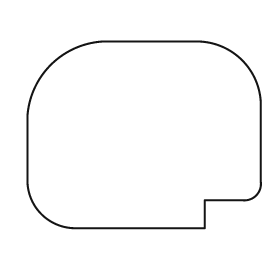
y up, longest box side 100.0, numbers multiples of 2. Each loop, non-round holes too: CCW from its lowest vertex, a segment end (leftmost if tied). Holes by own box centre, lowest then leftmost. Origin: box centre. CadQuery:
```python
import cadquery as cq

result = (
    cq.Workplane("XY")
    .moveTo(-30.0, -40.0)
    .lineTo(26.0, -40.0)
    .lineTo(26.0, -28.0)
    .lineTo(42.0, -28.0)
    .threePointArc((48.0, -26.0), (50.0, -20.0))
    .lineTo(50.0, 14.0)
    .threePointArc((42.0, 32.0), (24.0, 40.0))
    .lineTo(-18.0, 40.0)
    .threePointArc((-40.0, 30.0), (-50.0, 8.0))
    .lineTo(-50.0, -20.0)
    .threePointArc((-44.0, -34.0), (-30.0, -40.0))
    .close()
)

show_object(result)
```